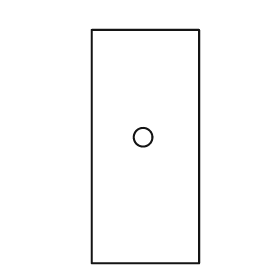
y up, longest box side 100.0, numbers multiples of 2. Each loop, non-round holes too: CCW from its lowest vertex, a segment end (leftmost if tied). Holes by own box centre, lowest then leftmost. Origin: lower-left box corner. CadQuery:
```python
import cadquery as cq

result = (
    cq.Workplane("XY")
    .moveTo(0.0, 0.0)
    .lineTo(46.0, 0.0)
    .lineTo(46.0, 100.0)
    .lineTo(0.0, 100.0)
    .close()
    .moveTo(22.0, 54.0)
    .circle(4.0)
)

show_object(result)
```